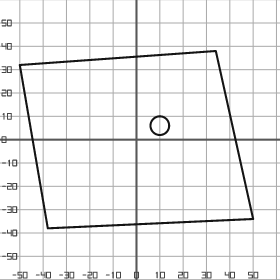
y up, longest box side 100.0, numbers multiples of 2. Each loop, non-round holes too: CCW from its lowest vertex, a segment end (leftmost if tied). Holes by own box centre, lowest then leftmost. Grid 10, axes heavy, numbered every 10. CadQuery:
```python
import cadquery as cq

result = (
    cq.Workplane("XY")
    .moveTo(-38.0, -38.0)
    .lineTo(50.0, -34.0)
    .lineTo(34.0, 38.0)
    .lineTo(-50.0, 32.0)
    .close()
    .moveTo(10.0, 6.0)
    .circle(4.0)
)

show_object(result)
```